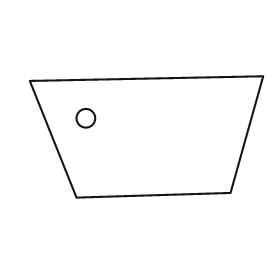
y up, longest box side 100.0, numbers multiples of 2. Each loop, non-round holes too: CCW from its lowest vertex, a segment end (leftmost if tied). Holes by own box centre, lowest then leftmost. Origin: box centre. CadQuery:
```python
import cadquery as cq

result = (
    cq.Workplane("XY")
    .moveTo(-30.0, -26.0)
    .lineTo(36.0, -24.0)
    .lineTo(50.0, 26.0)
    .lineTo(-50.0, 24.0)
    .close()
    .moveTo(-26.0, 8.0)
    .circle(4.0)
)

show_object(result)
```